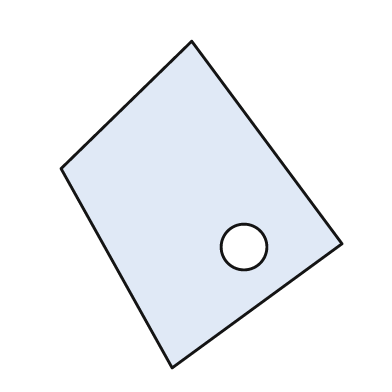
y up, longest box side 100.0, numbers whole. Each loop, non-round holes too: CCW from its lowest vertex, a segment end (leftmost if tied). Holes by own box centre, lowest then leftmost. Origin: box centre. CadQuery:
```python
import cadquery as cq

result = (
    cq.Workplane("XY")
    .moveTo(-9.0, -50.0)
    .lineTo(43.0, -12.0)
    .lineTo(-3.0, 50.0)
    .lineTo(-43.0, 11.0)
    .close()
    .moveTo(13.0, -13.0)
    .circle(7.0)
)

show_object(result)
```